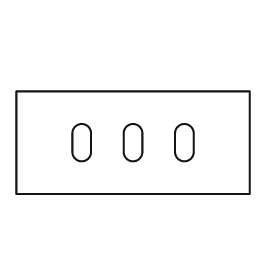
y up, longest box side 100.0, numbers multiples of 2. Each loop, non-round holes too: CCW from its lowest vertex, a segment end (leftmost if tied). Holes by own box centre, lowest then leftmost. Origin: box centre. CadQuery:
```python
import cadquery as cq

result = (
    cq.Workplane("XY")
    .moveTo(-50.0, -22.0)
    .lineTo(50.0, -22.0)
    .lineTo(50.0, 22.0)
    .lineTo(-50.0, 22.0)
    .close()
    .moveTo(-26.0, -4.0)
    .threePointArc((-22.0, -8.0), (-18.0, -4.0))
    .lineTo(-18.0, 4.0)
    .threePointArc((-22.0, 8.0), (-26.0, 4.0))
    .close()
    .moveTo(-4.0, -4.0)
    .threePointArc((0.0, -8.0), (4.0, -4.0))
    .lineTo(4.0, 4.0)
    .threePointArc((0.0, 8.0), (-4.0, 4.0))
    .close()
    .moveTo(18.0, -4.0)
    .threePointArc((22.0, -8.0), (26.0, -4.0))
    .lineTo(26.0, 4.0)
    .threePointArc((22.0, 8.0), (18.0, 4.0))
    .close()
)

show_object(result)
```